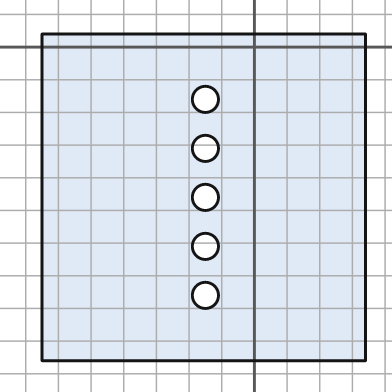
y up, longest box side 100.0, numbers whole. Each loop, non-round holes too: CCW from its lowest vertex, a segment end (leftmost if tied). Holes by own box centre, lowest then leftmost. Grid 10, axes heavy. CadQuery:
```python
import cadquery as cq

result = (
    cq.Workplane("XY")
    .moveTo(-65.0, -96.0)
    .lineTo(34.0, -96.0)
    .lineTo(34.0, 4.0)
    .lineTo(-65.0, 4.0)
    .close()
    .moveTo(-15.0, -76.0)
    .circle(4.0)
    .moveTo(-15.0, -61.0)
    .circle(4.0)
    .moveTo(-15.0, -46.0)
    .circle(4.0)
    .moveTo(-15.0, -31.0)
    .circle(4.0)
    .moveTo(-15.0, -16.0)
    .circle(4.0)
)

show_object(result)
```